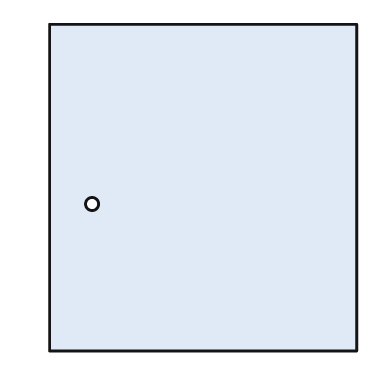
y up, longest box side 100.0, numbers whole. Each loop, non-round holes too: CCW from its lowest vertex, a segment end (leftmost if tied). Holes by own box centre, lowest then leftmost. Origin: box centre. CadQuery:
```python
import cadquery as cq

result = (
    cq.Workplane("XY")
    .moveTo(-47.0, -50.0)
    .lineTo(47.0, -50.0)
    .lineTo(47.0, 50.0)
    .lineTo(-47.0, 50.0)
    .close()
    .moveTo(-34.0, -5.0)
    .circle(2.0)
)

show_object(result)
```